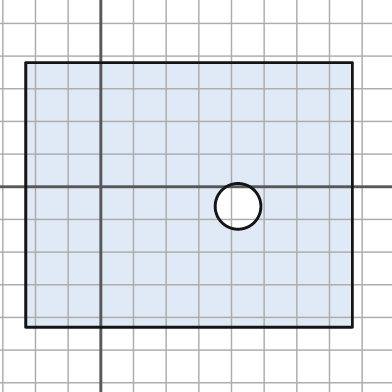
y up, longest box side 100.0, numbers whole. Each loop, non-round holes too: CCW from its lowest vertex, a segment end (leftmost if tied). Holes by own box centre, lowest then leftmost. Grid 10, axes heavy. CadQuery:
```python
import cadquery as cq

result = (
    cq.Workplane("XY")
    .moveTo(-23.0, -43.0)
    .lineTo(77.0, -43.0)
    .lineTo(77.0, 38.0)
    .lineTo(-23.0, 38.0)
    .close()
    .moveTo(42.0, -6.0)
    .circle(7.0)
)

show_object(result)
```